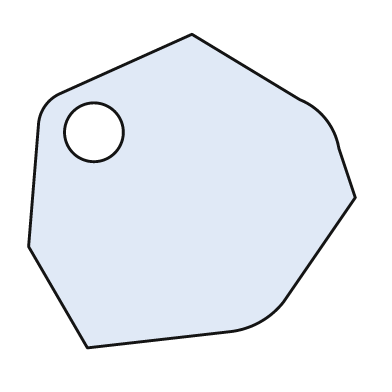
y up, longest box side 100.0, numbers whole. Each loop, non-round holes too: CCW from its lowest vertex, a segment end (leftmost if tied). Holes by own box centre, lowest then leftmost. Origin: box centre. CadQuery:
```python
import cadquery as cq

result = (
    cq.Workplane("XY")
    .moveTo(-32.0, -48.0)
    .lineTo(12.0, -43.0)
    .threePointArc((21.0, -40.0), (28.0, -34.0))
    .lineTo(50.0, -2.0)
    .lineTo(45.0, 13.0)
    .threePointArc((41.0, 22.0), (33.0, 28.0))
    .lineTo(0.0, 48.0)
    .lineTo(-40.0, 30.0)
    .threePointArc((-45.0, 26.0), (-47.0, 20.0))
    .lineTo(-50.0, -17.0)
    .close()
    .moveTo(-30.0, 18.0)
    .circle(9.0)
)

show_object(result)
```